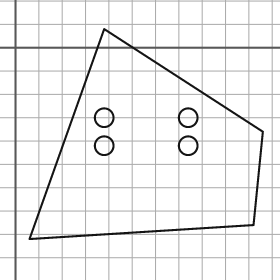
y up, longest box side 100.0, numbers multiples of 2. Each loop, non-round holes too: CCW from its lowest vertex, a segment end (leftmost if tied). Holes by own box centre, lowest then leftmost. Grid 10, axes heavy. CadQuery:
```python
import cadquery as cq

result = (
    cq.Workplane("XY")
    .moveTo(6.0, -82.0)
    .lineTo(102.0, -76.0)
    .lineTo(106.0, -36.0)
    .lineTo(38.0, 8.0)
    .close()
    .moveTo(38.0, -42.0)
    .circle(4.0)
    .moveTo(74.0, -42.0)
    .circle(4.0)
    .moveTo(38.0, -30.0)
    .circle(4.0)
    .moveTo(74.0, -30.0)
    .circle(4.0)
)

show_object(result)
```